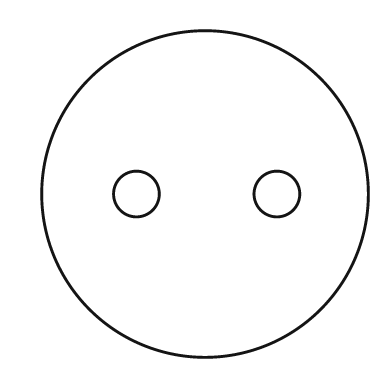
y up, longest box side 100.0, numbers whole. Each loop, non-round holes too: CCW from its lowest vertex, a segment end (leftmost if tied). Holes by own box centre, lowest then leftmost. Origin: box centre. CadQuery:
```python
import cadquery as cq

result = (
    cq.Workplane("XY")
    .moveTo(0.0, 0.0)
    .circle(50.0)
    .moveTo(-21.0, 0.0)
    .circle(7.0)
    .moveTo(22.0, 0.0)
    .circle(7.0)
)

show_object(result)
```